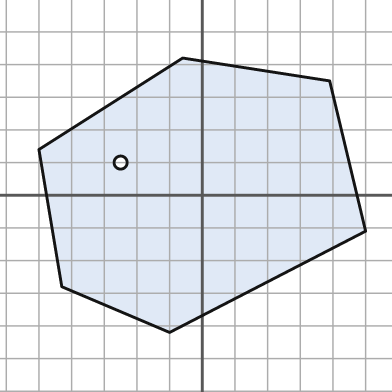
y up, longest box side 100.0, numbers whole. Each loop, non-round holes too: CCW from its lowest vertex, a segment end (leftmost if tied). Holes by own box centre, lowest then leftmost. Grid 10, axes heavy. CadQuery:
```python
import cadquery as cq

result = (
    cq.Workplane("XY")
    .moveTo(-10.0, -42.0)
    .lineTo(50.0, -11.0)
    .lineTo(39.0, 35.0)
    .lineTo(-6.0, 42.0)
    .lineTo(-50.0, 14.0)
    .lineTo(-43.0, -28.0)
    .close()
    .moveTo(-25.0, 10.0)
    .circle(2.0)
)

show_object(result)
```